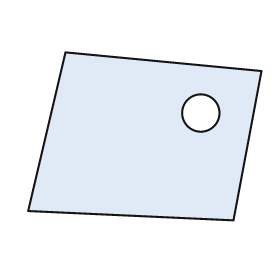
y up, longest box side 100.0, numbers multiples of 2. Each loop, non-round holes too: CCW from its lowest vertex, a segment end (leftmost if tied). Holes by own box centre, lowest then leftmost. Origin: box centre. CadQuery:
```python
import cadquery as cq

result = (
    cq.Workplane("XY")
    .moveTo(38.0, -36.0)
    .lineTo(50.0, 28.0)
    .lineTo(-34.0, 36.0)
    .lineTo(-50.0, -32.0)
    .close()
    .moveTo(24.0, 10.0)
    .circle(8.0)
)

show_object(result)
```